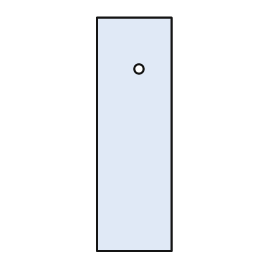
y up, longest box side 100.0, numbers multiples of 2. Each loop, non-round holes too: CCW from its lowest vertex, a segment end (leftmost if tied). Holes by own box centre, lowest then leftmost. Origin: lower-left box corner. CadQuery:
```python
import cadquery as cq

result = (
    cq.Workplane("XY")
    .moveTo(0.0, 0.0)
    .lineTo(32.0, 0.0)
    .lineTo(32.0, 100.0)
    .lineTo(0.0, 100.0)
    .close()
    .moveTo(18.0, 78.0)
    .circle(2.0)
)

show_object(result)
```